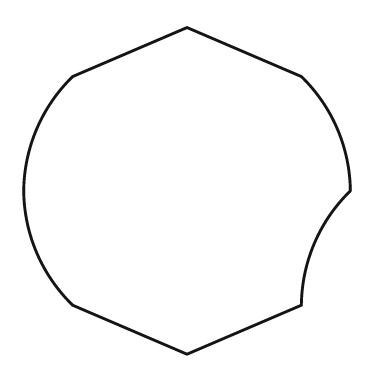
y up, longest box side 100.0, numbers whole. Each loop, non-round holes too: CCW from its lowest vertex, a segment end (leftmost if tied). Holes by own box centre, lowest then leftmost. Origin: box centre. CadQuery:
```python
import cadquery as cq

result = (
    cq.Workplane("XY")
    .moveTo(0.0, -50.0)
    .lineTo(35.0, -35.0)
    .threePointArc((39.0, -16.0), (50.0, 0.0))
    .threePointArc((46.0, 19.0), (35.0, 35.0))
    .lineTo(0.0, 50.0)
    .lineTo(-35.0, 35.0)
    .threePointArc((-46.0, 19.0), (-50.0, 0.0))
    .threePointArc((-46.0, -19.0), (-35.0, -35.0))
    .close()
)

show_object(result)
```